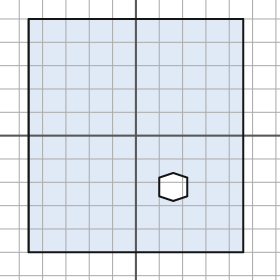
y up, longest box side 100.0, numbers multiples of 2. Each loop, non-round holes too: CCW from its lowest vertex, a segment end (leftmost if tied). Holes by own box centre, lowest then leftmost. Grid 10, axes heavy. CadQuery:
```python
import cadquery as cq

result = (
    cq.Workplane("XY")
    .moveTo(-46.0, -50.0)
    .lineTo(46.0, -50.0)
    .lineTo(46.0, 50.0)
    .lineTo(-46.0, 50.0)
    .close()
    .moveTo(16.0, -28.0)
    .lineTo(22.0, -26.0)
    .lineTo(22.0, -18.0)
    .lineTo(16.0, -16.0)
    .lineTo(10.0, -18.0)
    .lineTo(10.0, -26.0)
    .close()
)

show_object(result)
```